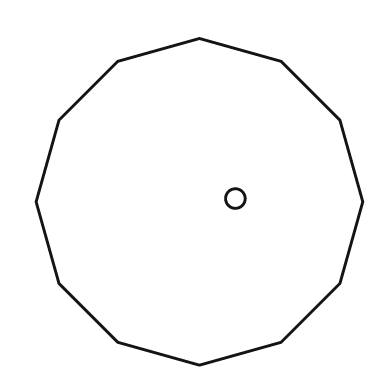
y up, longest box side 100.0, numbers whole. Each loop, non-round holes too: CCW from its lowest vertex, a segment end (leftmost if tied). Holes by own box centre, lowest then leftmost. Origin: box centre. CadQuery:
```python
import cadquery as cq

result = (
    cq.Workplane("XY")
    .moveTo(0.0, -50.0)
    .lineTo(25.0, -43.0)
    .lineTo(43.0, -25.0)
    .lineTo(50.0, 0.0)
    .lineTo(43.0, 25.0)
    .lineTo(25.0, 43.0)
    .lineTo(0.0, 50.0)
    .lineTo(-25.0, 43.0)
    .lineTo(-43.0, 25.0)
    .lineTo(-50.0, 0.0)
    .lineTo(-43.0, -25.0)
    .lineTo(-25.0, -43.0)
    .close()
    .moveTo(11.0, 1.0)
    .circle(3.0)
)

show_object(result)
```